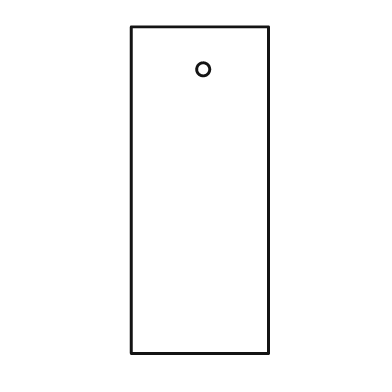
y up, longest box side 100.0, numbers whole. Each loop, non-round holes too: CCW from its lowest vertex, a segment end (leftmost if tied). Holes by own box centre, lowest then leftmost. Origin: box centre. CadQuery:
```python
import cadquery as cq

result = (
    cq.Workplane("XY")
    .moveTo(-21.0, -50.0)
    .lineTo(21.0, -50.0)
    .lineTo(21.0, 50.0)
    .lineTo(-21.0, 50.0)
    .close()
    .moveTo(1.0, 37.0)
    .circle(2.0)
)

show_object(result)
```